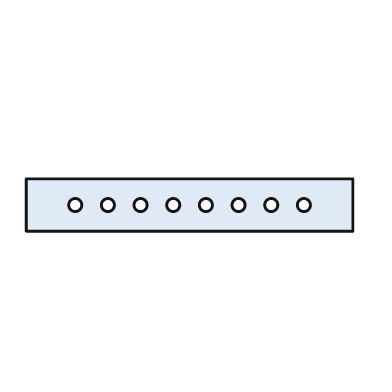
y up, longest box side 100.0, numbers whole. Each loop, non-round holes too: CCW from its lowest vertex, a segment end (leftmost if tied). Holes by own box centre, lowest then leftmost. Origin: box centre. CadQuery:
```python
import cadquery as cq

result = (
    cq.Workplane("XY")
    .moveTo(-50.0, -8.0)
    .lineTo(50.0, -8.0)
    .lineTo(50.0, 8.0)
    .lineTo(-50.0, 8.0)
    .close()
    .moveTo(-35.0, 0.0)
    .circle(2.0)
    .moveTo(-25.0, 0.0)
    .circle(2.0)
    .moveTo(-15.0, 0.0)
    .circle(2.0)
    .moveTo(-5.0, 0.0)
    .circle(2.0)
    .moveTo(5.0, 0.0)
    .circle(2.0)
    .moveTo(15.0, 0.0)
    .circle(2.0)
    .moveTo(25.0, 0.0)
    .circle(2.0)
    .moveTo(35.0, 0.0)
    .circle(2.0)
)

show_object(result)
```